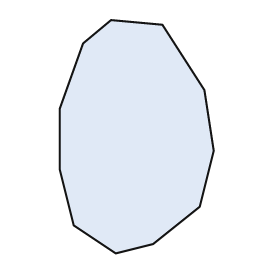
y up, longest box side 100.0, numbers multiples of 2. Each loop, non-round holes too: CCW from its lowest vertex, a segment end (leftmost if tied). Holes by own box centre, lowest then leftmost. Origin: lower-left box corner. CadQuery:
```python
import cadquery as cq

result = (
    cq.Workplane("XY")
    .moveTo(24.0, 0.0)
    .lineTo(40.0, 4.0)
    .lineTo(60.0, 20.0)
    .lineTo(66.0, 44.0)
    .lineTo(62.0, 70.0)
    .lineTo(44.0, 98.0)
    .lineTo(22.0, 100.0)
    .lineTo(10.0, 90.0)
    .lineTo(0.0, 62.0)
    .lineTo(0.0, 36.0)
    .lineTo(6.0, 12.0)
    .close()
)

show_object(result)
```